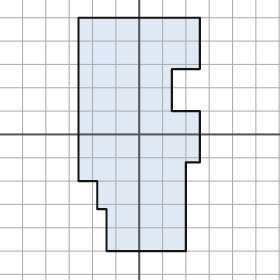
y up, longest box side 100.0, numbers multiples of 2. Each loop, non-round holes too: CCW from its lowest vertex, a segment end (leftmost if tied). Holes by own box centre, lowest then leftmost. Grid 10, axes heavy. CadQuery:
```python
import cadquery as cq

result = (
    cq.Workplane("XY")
    .moveTo(-14.0, -50.0)
    .lineTo(20.0, -50.0)
    .lineTo(20.0, -12.0)
    .lineTo(26.0, -12.0)
    .lineTo(26.0, 10.0)
    .lineTo(14.0, 10.0)
    .lineTo(14.0, 28.0)
    .lineTo(26.0, 28.0)
    .lineTo(26.0, 50.0)
    .lineTo(-26.0, 50.0)
    .lineTo(-26.0, -20.0)
    .lineTo(-18.0, -20.0)
    .lineTo(-18.0, -32.0)
    .lineTo(-14.0, -32.0)
    .close()
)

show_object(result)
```